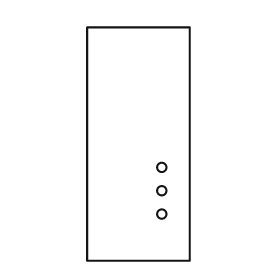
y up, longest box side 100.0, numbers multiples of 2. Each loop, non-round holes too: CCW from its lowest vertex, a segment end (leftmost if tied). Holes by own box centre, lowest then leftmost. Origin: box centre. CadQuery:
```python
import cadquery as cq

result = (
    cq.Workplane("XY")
    .moveTo(-22.0, -50.0)
    .lineTo(22.0, -50.0)
    .lineTo(22.0, 50.0)
    .lineTo(-22.0, 50.0)
    .close()
    .moveTo(10.0, -30.0)
    .circle(2.0)
    .moveTo(10.0, -20.0)
    .circle(2.0)
    .moveTo(10.0, -10.0)
    .circle(2.0)
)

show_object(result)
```